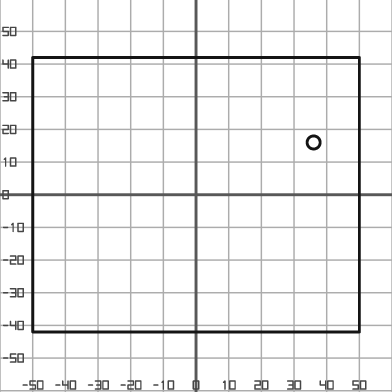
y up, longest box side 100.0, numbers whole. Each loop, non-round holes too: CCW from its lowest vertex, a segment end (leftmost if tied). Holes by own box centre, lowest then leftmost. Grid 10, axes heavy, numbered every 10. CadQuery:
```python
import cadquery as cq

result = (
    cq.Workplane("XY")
    .moveTo(-50.0, -42.0)
    .lineTo(50.0, -42.0)
    .lineTo(50.0, 42.0)
    .lineTo(-50.0, 42.0)
    .close()
    .moveTo(36.0, 16.0)
    .circle(2.0)
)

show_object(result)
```